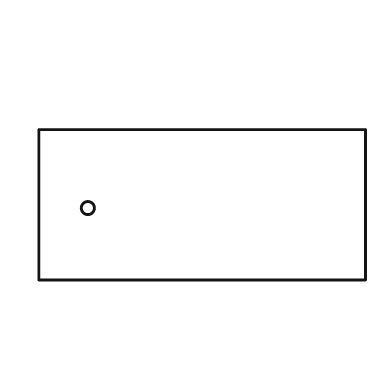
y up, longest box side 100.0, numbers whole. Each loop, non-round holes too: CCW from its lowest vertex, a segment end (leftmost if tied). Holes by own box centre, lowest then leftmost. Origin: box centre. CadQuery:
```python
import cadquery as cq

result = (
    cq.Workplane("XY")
    .moveTo(-50.0, -23.0)
    .lineTo(50.0, -23.0)
    .lineTo(50.0, 23.0)
    .lineTo(-50.0, 23.0)
    .close()
    .moveTo(-35.0, -1.0)
    .circle(2.0)
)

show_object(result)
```